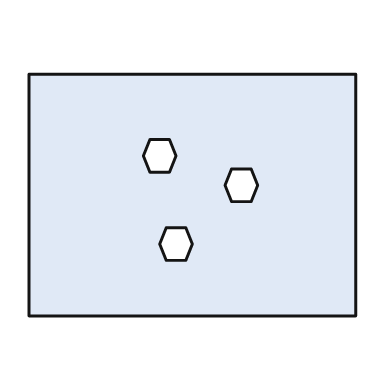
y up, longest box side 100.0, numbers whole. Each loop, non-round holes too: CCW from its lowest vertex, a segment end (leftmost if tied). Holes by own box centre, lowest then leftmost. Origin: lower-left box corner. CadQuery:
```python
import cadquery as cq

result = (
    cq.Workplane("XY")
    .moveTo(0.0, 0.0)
    .lineTo(100.0, 0.0)
    .lineTo(100.0, 74.0)
    .lineTo(0.0, 74.0)
    .close()
    .moveTo(42.0, 17.0)
    .lineTo(48.0, 17.0)
    .lineTo(50.0, 22.0)
    .lineTo(48.0, 27.0)
    .lineTo(42.0, 27.0)
    .lineTo(40.0, 22.0)
    .close()
    .moveTo(62.0, 35.0)
    .lineTo(68.0, 35.0)
    .lineTo(70.0, 40.0)
    .lineTo(68.0, 45.0)
    .lineTo(62.0, 45.0)
    .lineTo(60.0, 40.0)
    .close()
    .moveTo(37.0, 44.0)
    .lineTo(43.0, 44.0)
    .lineTo(45.0, 49.0)
    .lineTo(43.0, 54.0)
    .lineTo(37.0, 54.0)
    .lineTo(35.0, 49.0)
    .close()
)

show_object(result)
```